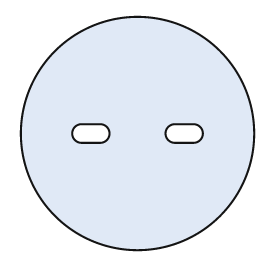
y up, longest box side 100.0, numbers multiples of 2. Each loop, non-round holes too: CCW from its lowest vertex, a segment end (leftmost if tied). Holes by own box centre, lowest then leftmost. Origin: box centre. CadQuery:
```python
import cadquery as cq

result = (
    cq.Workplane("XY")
    .moveTo(0.0, 0.0)
    .circle(50.0)
    .moveTo(-24.0, -4.0)
    .lineTo(-16.0, -4.0)
    .threePointArc((-12.0, 0.0), (-16.0, 4.0))
    .lineTo(-24.0, 4.0)
    .threePointArc((-28.0, 0.0), (-24.0, -4.0))
    .close()
    .moveTo(16.0, -4.0)
    .lineTo(24.0, -4.0)
    .threePointArc((28.0, 0.0), (24.0, 4.0))
    .lineTo(16.0, 4.0)
    .threePointArc((12.0, 0.0), (16.0, -4.0))
    .close()
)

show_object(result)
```